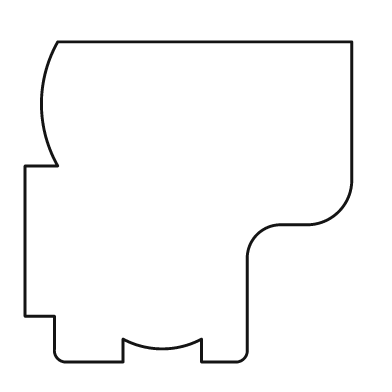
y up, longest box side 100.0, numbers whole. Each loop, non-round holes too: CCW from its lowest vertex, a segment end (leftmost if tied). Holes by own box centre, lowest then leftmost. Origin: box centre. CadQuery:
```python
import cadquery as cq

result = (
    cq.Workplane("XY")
    .moveTo(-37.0, -49.0)
    .lineTo(-20.0, -49.0)
    .lineTo(-20.0, -42.0)
    .threePointArc((-8.0, -45.0), (4.0, -42.0))
    .lineTo(4.0, -49.0)
    .lineTo(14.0, -49.0)
    .threePointArc((17.0, -48.0), (18.0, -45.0))
    .lineTo(18.0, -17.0)
    .threePointArc((21.0, -10.0), (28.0, -7.0))
    .lineTo(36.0, -7.0)
    .threePointArc((46.0, -3.0), (50.0, 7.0))
    .lineTo(50.0, 49.0)
    .lineTo(-40.0, 49.0)
    .threePointArc((-45.0, 30.0), (-40.0, 11.0))
    .lineTo(-50.0, 11.0)
    .lineTo(-50.0, -35.0)
    .lineTo(-41.0, -35.0)
    .lineTo(-41.0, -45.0)
    .threePointArc((-40.0, -48.0), (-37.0, -49.0))
    .close()
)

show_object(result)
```